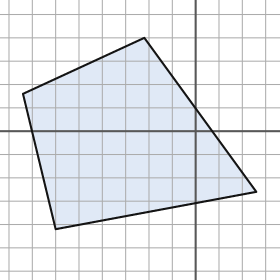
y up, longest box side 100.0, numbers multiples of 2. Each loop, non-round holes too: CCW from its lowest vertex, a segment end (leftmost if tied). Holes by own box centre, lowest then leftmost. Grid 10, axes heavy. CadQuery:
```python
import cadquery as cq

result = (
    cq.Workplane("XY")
    .moveTo(-60.0, -42.0)
    .lineTo(26.0, -26.0)
    .lineTo(-22.0, 40.0)
    .lineTo(-74.0, 16.0)
    .close()
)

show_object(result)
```